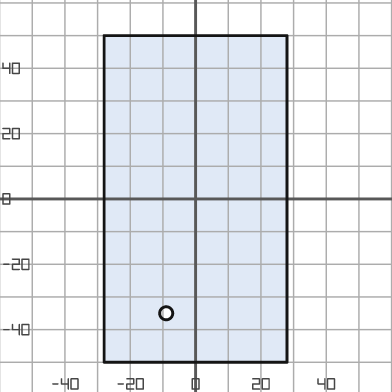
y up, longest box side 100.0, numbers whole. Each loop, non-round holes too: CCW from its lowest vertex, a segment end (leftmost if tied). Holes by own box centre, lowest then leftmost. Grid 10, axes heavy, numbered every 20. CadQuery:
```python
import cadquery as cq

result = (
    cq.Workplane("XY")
    .moveTo(-28.0, -50.0)
    .lineTo(28.0, -50.0)
    .lineTo(28.0, 50.0)
    .lineTo(-28.0, 50.0)
    .close()
    .moveTo(-9.0, -35.0)
    .circle(2.0)
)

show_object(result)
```